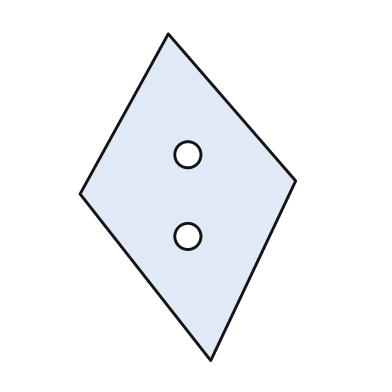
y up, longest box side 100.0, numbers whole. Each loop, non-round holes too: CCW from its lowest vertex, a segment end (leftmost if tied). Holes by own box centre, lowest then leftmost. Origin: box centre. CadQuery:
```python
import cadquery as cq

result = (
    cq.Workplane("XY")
    .moveTo(7.0, -50.0)
    .lineTo(33.0, 5.0)
    .lineTo(-6.0, 50.0)
    .lineTo(-33.0, 1.0)
    .close()
    .moveTo(0.0, -12.0)
    .circle(4.0)
    .moveTo(0.0, 13.0)
    .circle(4.0)
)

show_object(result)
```